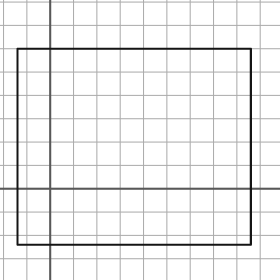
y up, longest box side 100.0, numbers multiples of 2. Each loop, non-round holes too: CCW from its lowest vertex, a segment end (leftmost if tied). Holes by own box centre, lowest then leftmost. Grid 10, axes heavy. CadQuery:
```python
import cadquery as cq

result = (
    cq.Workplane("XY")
    .moveTo(-14.0, -24.0)
    .lineTo(86.0, -24.0)
    .lineTo(86.0, 60.0)
    .lineTo(-14.0, 60.0)
    .close()
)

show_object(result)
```